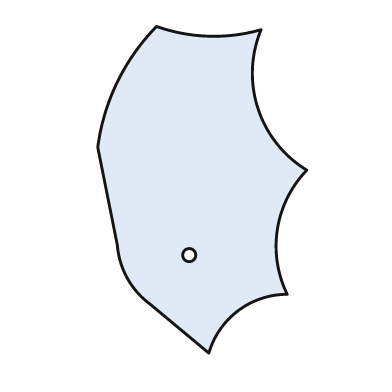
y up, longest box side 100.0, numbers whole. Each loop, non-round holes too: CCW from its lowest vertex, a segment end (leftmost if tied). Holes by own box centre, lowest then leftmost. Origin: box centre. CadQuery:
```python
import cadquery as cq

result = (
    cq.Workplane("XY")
    .moveTo(2.0, -50.0)
    .threePointArc((11.0, -37.0), (26.0, -32.0))
    .threePointArc((23.0, -12.0), (32.0, 6.0))
    .threePointArc((17.0, 25.0), (18.0, 49.0))
    .threePointArc((2.0, 47.0), (-14.0, 50.0))
    .threePointArc((-26.0, 33.0), (-32.0, 13.0))
    .lineTo(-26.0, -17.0)
    .threePointArc((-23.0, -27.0), (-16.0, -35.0))
    .close()
    .moveTo(-4.0, -20.0)
    .circle(2.0)
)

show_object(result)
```